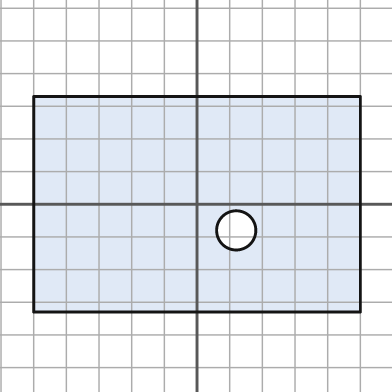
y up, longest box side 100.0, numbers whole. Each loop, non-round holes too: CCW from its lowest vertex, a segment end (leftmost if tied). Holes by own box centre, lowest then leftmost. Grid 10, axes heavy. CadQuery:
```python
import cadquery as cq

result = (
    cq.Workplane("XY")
    .moveTo(-50.0, -33.0)
    .lineTo(50.0, -33.0)
    .lineTo(50.0, 33.0)
    .lineTo(-50.0, 33.0)
    .close()
    .moveTo(12.0, -8.0)
    .circle(6.0)
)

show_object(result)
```